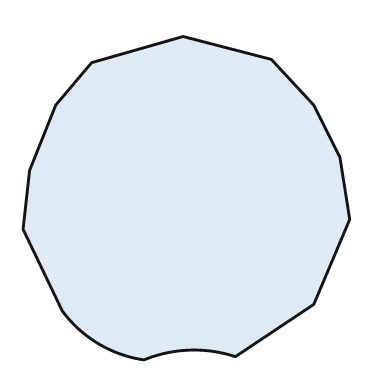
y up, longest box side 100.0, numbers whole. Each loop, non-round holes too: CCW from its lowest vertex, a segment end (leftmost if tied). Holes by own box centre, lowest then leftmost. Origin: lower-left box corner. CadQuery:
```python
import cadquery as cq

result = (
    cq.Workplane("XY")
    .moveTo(37.0, 0.0)
    .threePointArc((51.0, 3.0), (65.0, 1.0))
    .lineTo(89.0, 17.0)
    .lineTo(100.0, 43.0)
    .lineTo(97.0, 62.0)
    .lineTo(89.0, 78.0)
    .lineTo(76.0, 92.0)
    .lineTo(49.0, 99.0)
    .lineTo(21.0, 91.0)
    .lineTo(10.0, 78.0)
    .lineTo(2.0, 58.0)
    .lineTo(0.0, 40.0)
    .lineTo(12.0, 15.0)
    .threePointArc((23.0, 5.0), (37.0, 0.0))
    .close()
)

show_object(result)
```